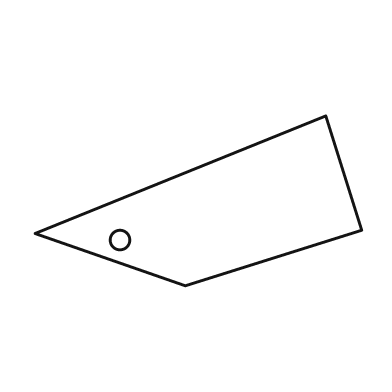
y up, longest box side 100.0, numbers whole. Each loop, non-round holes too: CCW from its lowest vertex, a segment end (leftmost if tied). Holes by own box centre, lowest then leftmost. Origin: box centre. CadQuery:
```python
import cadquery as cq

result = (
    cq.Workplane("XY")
    .moveTo(-4.0, -26.0)
    .lineTo(50.0, -9.0)
    .lineTo(39.0, 26.0)
    .lineTo(-50.0, -10.0)
    .close()
    .moveTo(-24.0, -12.0)
    .circle(3.0)
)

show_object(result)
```